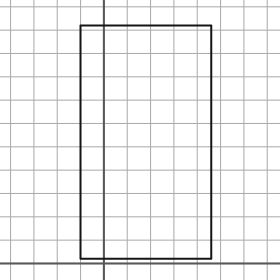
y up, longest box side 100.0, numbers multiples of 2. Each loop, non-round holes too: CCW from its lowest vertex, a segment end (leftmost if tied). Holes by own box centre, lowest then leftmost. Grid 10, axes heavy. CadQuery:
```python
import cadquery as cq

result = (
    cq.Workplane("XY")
    .moveTo(-10.0, 2.0)
    .lineTo(46.0, 2.0)
    .lineTo(46.0, 102.0)
    .lineTo(-10.0, 102.0)
    .close()
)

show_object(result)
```